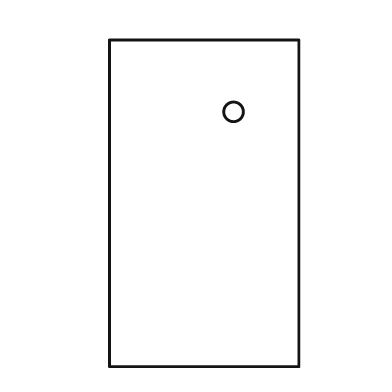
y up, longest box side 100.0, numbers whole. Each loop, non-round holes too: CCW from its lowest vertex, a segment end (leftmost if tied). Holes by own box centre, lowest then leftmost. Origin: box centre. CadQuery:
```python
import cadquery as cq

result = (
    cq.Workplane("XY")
    .moveTo(-29.0, -50.0)
    .lineTo(29.0, -50.0)
    .lineTo(29.0, 50.0)
    .lineTo(-29.0, 50.0)
    .close()
    .moveTo(9.0, 28.0)
    .circle(3.0)
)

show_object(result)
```